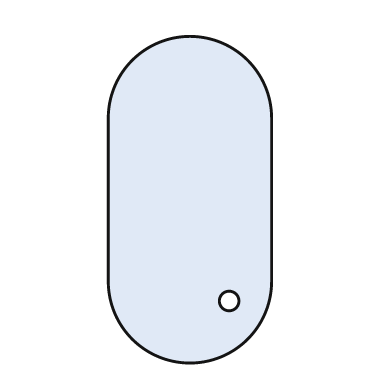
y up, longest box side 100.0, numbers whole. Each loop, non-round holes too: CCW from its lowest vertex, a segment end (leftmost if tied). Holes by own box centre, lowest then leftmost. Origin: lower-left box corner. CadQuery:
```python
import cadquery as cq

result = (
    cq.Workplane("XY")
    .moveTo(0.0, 25.0)
    .threePointArc((25.0, 0.0), (50.0, 25.0))
    .lineTo(50.0, 75.0)
    .threePointArc((25.0, 100.0), (0.0, 75.0))
    .close()
    .moveTo(37.0, 19.0)
    .circle(3.0)
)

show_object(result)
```